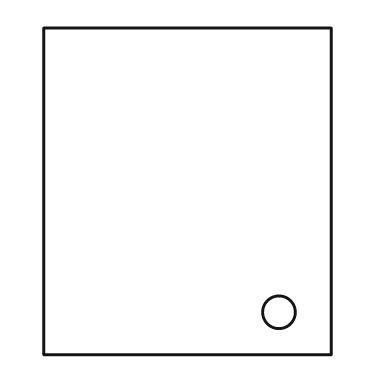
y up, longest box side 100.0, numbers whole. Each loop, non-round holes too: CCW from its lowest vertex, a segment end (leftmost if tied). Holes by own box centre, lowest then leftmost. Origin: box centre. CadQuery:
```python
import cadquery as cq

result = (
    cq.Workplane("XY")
    .moveTo(-44.0, -50.0)
    .lineTo(44.0, -50.0)
    .lineTo(44.0, 50.0)
    .lineTo(-44.0, 50.0)
    .close()
    .moveTo(28.0, -37.0)
    .circle(5.0)
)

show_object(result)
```